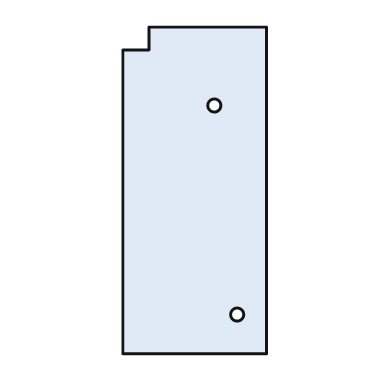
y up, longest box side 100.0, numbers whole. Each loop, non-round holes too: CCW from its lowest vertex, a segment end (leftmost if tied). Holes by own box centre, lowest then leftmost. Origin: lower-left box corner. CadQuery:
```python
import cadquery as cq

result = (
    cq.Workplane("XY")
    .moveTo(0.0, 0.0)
    .lineTo(44.0, 0.0)
    .lineTo(44.0, 100.0)
    .lineTo(8.0, 100.0)
    .lineTo(8.0, 93.0)
    .lineTo(0.0, 93.0)
    .close()
    .moveTo(35.0, 12.0)
    .circle(2.0)
    .moveTo(28.0, 76.0)
    .circle(2.0)
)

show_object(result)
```